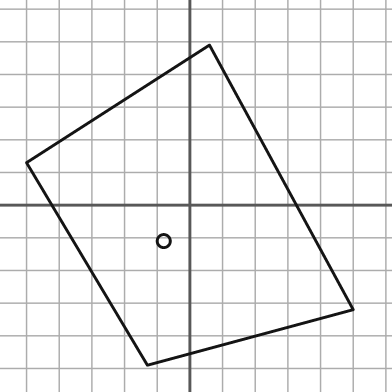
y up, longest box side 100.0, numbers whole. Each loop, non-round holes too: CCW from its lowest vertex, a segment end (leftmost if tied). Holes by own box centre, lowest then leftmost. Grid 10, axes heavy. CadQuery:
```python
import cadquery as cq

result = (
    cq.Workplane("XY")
    .moveTo(-13.0, -49.0)
    .lineTo(50.0, -32.0)
    .lineTo(6.0, 49.0)
    .lineTo(-50.0, 13.0)
    .close()
    .moveTo(-8.0, -11.0)
    .circle(2.0)
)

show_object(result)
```